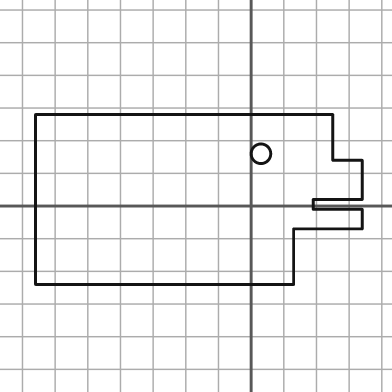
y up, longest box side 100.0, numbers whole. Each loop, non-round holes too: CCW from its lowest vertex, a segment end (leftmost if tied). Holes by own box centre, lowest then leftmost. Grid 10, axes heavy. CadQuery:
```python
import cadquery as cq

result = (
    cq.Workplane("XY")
    .moveTo(-66.0, -24.0)
    .lineTo(13.0, -24.0)
    .lineTo(13.0, -7.0)
    .lineTo(34.0, -7.0)
    .lineTo(34.0, -1.0)
    .lineTo(19.0, -1.0)
    .lineTo(19.0, 2.0)
    .lineTo(34.0, 2.0)
    .lineTo(34.0, 14.0)
    .lineTo(25.0, 14.0)
    .lineTo(25.0, 28.0)
    .lineTo(-66.0, 28.0)
    .close()
    .moveTo(3.0, 16.0)
    .circle(3.0)
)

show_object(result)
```